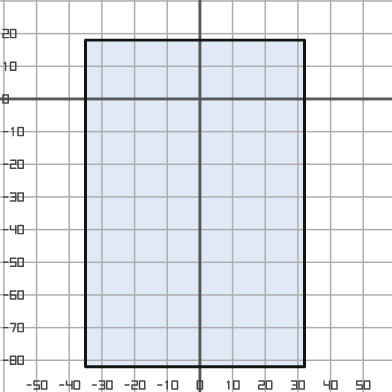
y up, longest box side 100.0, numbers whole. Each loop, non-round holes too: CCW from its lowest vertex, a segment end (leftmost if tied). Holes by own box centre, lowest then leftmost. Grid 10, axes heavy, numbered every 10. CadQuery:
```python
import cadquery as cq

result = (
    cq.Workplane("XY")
    .moveTo(-35.0, -82.0)
    .lineTo(32.0, -82.0)
    .lineTo(32.0, 18.0)
    .lineTo(-35.0, 18.0)
    .close()
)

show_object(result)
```